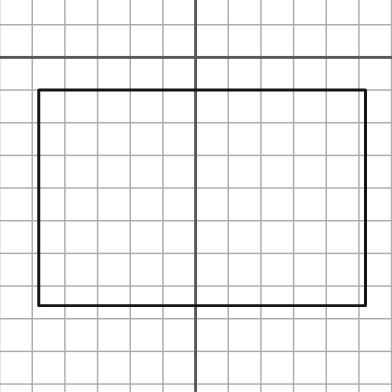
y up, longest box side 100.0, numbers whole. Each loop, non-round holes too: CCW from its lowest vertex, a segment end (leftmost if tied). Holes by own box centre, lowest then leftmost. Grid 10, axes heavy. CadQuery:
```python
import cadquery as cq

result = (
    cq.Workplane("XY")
    .moveTo(-48.0, -76.0)
    .lineTo(52.0, -76.0)
    .lineTo(52.0, -10.0)
    .lineTo(-48.0, -10.0)
    .close()
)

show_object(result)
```